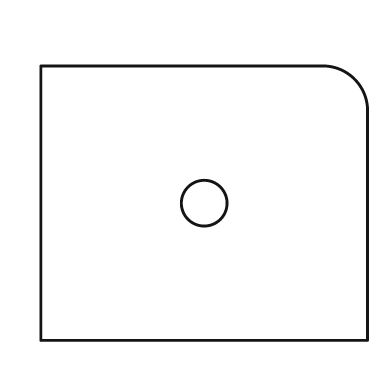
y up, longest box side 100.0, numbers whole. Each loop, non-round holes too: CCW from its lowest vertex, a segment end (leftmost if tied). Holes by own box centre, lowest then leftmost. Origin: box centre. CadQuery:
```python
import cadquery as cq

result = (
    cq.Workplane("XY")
    .moveTo(-50.0, -42.0)
    .lineTo(50.0, -42.0)
    .lineTo(50.0, 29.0)
    .threePointArc((46.0, 38.0), (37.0, 42.0))
    .lineTo(-50.0, 42.0)
    .close()
    .moveTo(0.0, 0.0)
    .circle(7.0)
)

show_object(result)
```